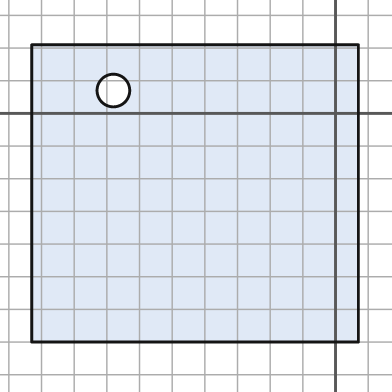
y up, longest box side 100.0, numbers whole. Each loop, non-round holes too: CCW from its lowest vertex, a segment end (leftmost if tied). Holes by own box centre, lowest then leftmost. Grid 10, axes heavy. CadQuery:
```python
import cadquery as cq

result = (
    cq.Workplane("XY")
    .moveTo(-93.0, -70.0)
    .lineTo(7.0, -70.0)
    .lineTo(7.0, 21.0)
    .lineTo(-93.0, 21.0)
    .close()
    .moveTo(-68.0, 7.0)
    .circle(5.0)
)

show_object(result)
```